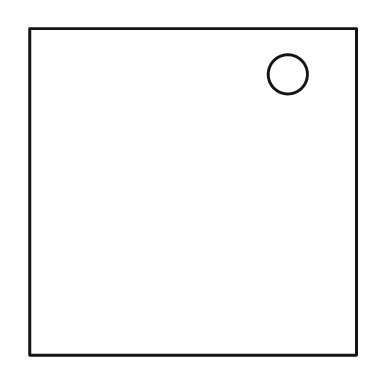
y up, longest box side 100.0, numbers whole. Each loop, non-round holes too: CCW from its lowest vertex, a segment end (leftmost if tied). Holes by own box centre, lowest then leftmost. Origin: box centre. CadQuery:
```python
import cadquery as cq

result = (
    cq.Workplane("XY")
    .moveTo(-50.0, -50.0)
    .lineTo(50.0, -50.0)
    .lineTo(50.0, 50.0)
    .lineTo(-50.0, 50.0)
    .close()
    .moveTo(29.0, 36.0)
    .circle(6.0)
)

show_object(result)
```